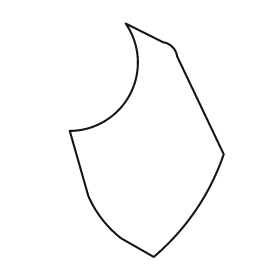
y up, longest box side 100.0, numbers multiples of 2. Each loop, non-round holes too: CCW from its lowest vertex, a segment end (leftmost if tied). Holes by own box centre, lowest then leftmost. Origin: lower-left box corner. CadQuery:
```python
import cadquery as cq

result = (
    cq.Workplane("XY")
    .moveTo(36.0, 0.0)
    .threePointArc((54.0, 20.0), (66.0, 44.0))
    .lineTo(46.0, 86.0)
    .threePointArc((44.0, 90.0), (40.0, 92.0))
    .lineTo(24.0, 100.0)
    .threePointArc((26.0, 70.0), (0.0, 54.0))
    .lineTo(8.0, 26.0)
    .threePointArc((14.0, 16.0), (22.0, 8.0))
    .close()
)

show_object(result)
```